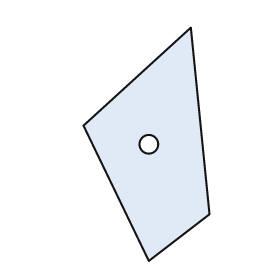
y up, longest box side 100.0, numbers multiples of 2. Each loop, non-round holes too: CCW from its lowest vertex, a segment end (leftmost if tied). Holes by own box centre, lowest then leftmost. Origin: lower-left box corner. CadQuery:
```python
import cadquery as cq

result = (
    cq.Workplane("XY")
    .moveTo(28.0, 0.0)
    .lineTo(54.0, 20.0)
    .lineTo(46.0, 100.0)
    .lineTo(0.0, 58.0)
    .close()
    .moveTo(28.0, 50.0)
    .circle(4.0)
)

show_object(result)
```